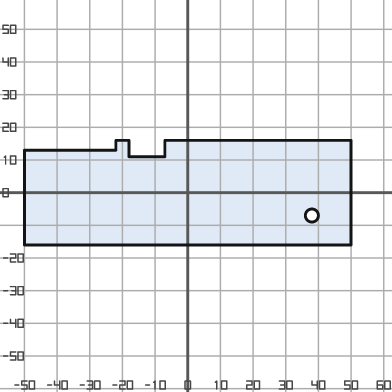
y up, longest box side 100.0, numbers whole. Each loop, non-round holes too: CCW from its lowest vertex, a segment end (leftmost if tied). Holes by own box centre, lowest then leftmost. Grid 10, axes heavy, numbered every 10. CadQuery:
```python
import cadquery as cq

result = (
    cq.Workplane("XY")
    .moveTo(-50.0, -16.0)
    .lineTo(50.0, -16.0)
    .lineTo(50.0, 16.0)
    .lineTo(-7.0, 16.0)
    .lineTo(-7.0, 11.0)
    .lineTo(-18.0, 11.0)
    .lineTo(-18.0, 16.0)
    .lineTo(-22.0, 16.0)
    .lineTo(-22.0, 13.0)
    .lineTo(-50.0, 13.0)
    .close()
    .moveTo(38.0, -7.0)
    .circle(2.0)
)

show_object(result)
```